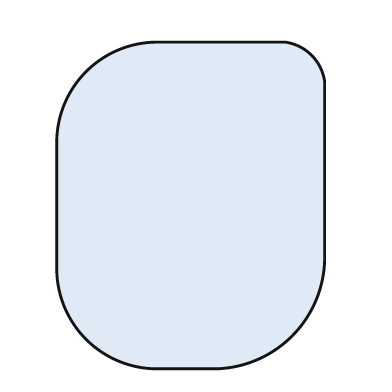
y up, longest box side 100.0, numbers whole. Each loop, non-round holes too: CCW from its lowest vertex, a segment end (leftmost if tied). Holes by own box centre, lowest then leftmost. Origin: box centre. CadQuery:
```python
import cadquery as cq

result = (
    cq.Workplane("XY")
    .moveTo(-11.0, -50.0)
    .lineTo(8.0, -50.0)
    .threePointArc((31.0, -40.0), (41.0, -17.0))
    .lineTo(41.0, 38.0)
    .threePointArc((37.0, 46.0), (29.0, 50.0))
    .lineTo(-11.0, 50.0)
    .threePointArc((-32.0, 41.0), (-41.0, 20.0))
    .lineTo(-41.0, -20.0)
    .threePointArc((-32.0, -41.0), (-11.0, -50.0))
    .close()
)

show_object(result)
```